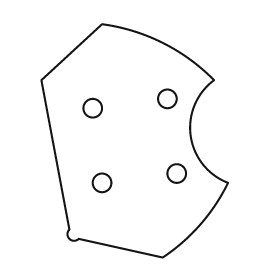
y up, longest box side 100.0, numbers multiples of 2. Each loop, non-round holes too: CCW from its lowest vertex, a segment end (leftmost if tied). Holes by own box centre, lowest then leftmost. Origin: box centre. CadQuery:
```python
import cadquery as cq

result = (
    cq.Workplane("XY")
    .moveTo(12.0, -50.0)
    .threePointArc((28.0, -36.0), (40.0, -18.0))
    .threePointArc((24.0, 2.0), (34.0, 26.0))
    .threePointArc((12.0, 42.0), (-14.0, 50.0))
    .lineTo(-40.0, 26.0)
    .lineTo(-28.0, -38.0)
    .threePointArc((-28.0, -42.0), (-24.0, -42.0))
    .close()
    .moveTo(-14.0, -18.0)
    .circle(4.0)
    .moveTo(18.0, -14.0)
    .circle(4.0)
    .moveTo(-18.0, 14.0)
    .circle(4.0)
    .moveTo(14.0, 18.0)
    .circle(4.0)
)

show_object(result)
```